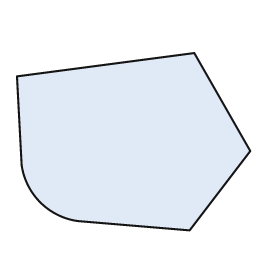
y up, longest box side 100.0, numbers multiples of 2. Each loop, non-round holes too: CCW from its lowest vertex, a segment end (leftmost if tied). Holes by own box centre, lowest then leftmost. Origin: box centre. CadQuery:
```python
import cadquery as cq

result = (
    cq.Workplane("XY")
    .moveTo(24.0, -38.0)
    .lineTo(50.0, -4.0)
    .lineTo(26.0, 38.0)
    .lineTo(-50.0, 28.0)
    .lineTo(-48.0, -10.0)
    .threePointArc((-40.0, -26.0), (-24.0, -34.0))
    .close()
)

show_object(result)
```